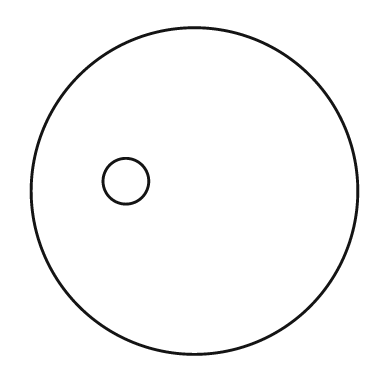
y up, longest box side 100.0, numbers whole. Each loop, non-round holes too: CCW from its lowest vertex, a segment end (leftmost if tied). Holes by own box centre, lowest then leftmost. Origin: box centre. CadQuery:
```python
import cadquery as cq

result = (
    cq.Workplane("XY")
    .moveTo(0.0, 0.0)
    .circle(50.0)
    .moveTo(-21.0, 3.0)
    .circle(7.0)
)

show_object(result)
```